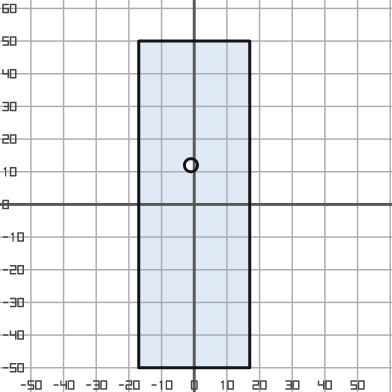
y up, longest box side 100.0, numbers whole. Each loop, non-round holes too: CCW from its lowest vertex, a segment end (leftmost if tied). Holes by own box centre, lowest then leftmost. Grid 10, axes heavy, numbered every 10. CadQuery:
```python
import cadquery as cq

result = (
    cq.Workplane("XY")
    .moveTo(-17.0, -50.0)
    .lineTo(17.0, -50.0)
    .lineTo(17.0, 50.0)
    .lineTo(-17.0, 50.0)
    .close()
    .moveTo(-1.0, 12.0)
    .circle(2.0)
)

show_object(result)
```